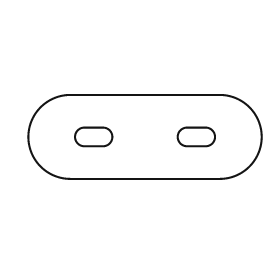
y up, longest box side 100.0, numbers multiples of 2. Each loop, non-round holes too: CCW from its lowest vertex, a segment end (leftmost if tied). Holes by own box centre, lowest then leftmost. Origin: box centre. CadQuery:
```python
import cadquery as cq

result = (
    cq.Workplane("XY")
    .moveTo(-32.0, -18.0)
    .lineTo(32.0, -18.0)
    .threePointArc((50.0, 0.0), (32.0, 18.0))
    .lineTo(-32.0, 18.0)
    .threePointArc((-50.0, 0.0), (-32.0, -18.0))
    .close()
    .moveTo(-26.0, -4.0)
    .lineTo(-18.0, -4.0)
    .threePointArc((-14.0, 0.0), (-18.0, 4.0))
    .lineTo(-26.0, 4.0)
    .threePointArc((-30.0, 0.0), (-26.0, -4.0))
    .close()
    .moveTo(18.0, -4.0)
    .lineTo(26.0, -4.0)
    .threePointArc((30.0, 0.0), (26.0, 4.0))
    .lineTo(18.0, 4.0)
    .threePointArc((14.0, 0.0), (18.0, -4.0))
    .close()
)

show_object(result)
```